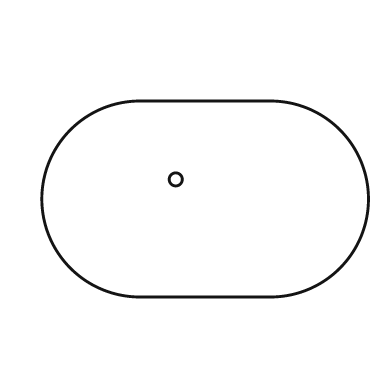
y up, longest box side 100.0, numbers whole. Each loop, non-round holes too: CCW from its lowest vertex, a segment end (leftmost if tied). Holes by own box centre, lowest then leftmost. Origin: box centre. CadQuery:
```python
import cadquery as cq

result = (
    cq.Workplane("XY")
    .moveTo(-20.0, -30.0)
    .lineTo(20.0, -30.0)
    .threePointArc((50.0, 0.0), (20.0, 30.0))
    .lineTo(-20.0, 30.0)
    .threePointArc((-50.0, 0.0), (-20.0, -30.0))
    .close()
    .moveTo(-9.0, 6.0)
    .circle(2.0)
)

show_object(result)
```